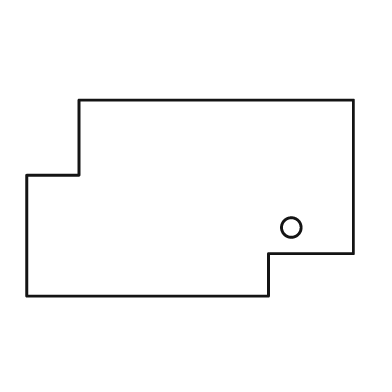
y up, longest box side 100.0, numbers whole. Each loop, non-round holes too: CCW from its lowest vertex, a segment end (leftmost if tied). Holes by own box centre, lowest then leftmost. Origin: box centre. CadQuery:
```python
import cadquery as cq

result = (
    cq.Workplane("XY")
    .moveTo(-50.0, -30.0)
    .lineTo(24.0, -30.0)
    .lineTo(24.0, -17.0)
    .lineTo(50.0, -17.0)
    .lineTo(50.0, 30.0)
    .lineTo(-34.0, 30.0)
    .lineTo(-34.0, 7.0)
    .lineTo(-50.0, 7.0)
    .close()
    .moveTo(31.0, -9.0)
    .circle(3.0)
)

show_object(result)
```